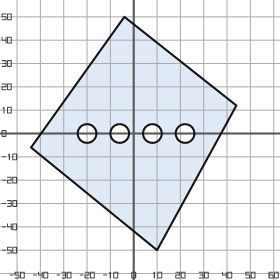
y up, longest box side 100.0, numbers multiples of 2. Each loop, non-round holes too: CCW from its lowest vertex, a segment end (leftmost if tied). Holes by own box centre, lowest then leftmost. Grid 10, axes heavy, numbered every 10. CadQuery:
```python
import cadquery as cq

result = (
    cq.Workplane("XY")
    .moveTo(10.0, -50.0)
    .lineTo(44.0, 12.0)
    .lineTo(-4.0, 50.0)
    .lineTo(-44.0, -6.0)
    .close()
    .moveTo(-20.0, 0.0)
    .circle(4.0)
    .moveTo(-6.0, 0.0)
    .circle(4.0)
    .moveTo(8.0, 0.0)
    .circle(4.0)
    .moveTo(22.0, 0.0)
    .circle(4.0)
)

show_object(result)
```